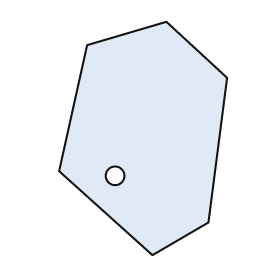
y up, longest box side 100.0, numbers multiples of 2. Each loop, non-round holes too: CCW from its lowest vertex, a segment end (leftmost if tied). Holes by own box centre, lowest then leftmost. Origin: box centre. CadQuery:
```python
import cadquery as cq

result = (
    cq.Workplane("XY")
    .moveTo(4.0, -50.0)
    .lineTo(28.0, -36.0)
    .lineTo(36.0, 26.0)
    .lineTo(10.0, 50.0)
    .lineTo(-24.0, 40.0)
    .lineTo(-36.0, -14.0)
    .close()
    .moveTo(-12.0, -16.0)
    .circle(4.0)
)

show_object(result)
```